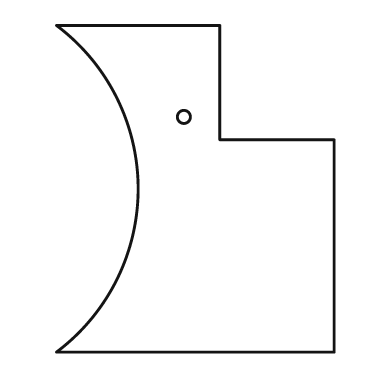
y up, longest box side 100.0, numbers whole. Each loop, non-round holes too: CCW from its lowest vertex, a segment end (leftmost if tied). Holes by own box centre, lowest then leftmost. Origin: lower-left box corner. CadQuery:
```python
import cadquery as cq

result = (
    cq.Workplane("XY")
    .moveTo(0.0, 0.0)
    .lineTo(85.0, 0.0)
    .lineTo(85.0, 65.0)
    .lineTo(50.0, 65.0)
    .lineTo(50.0, 100.0)
    .lineTo(0.0, 100.0)
    .threePointArc((25.0, 50.0), (0.0, 0.0))
    .close()
    .moveTo(39.0, 72.0)
    .circle(2.0)
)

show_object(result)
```